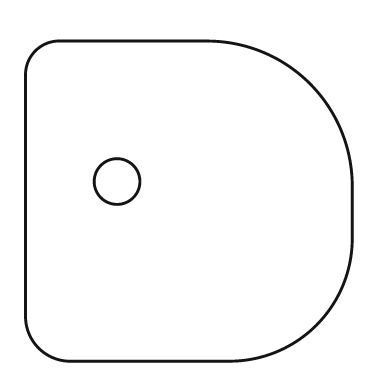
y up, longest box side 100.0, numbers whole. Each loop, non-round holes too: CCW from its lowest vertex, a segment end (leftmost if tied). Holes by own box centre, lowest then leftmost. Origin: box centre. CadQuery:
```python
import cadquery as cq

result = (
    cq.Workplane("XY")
    .moveTo(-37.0, -49.0)
    .lineTo(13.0, -49.0)
    .threePointArc((39.0, -38.0), (50.0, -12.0))
    .lineTo(50.0, 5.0)
    .threePointArc((37.0, 36.0), (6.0, 49.0))
    .lineTo(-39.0, 49.0)
    .threePointArc((-47.0, 46.0), (-50.0, 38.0))
    .lineTo(-50.0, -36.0)
    .threePointArc((-46.0, -45.0), (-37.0, -49.0))
    .close()
    .moveTo(-22.0, 6.0)
    .circle(7.0)
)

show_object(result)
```